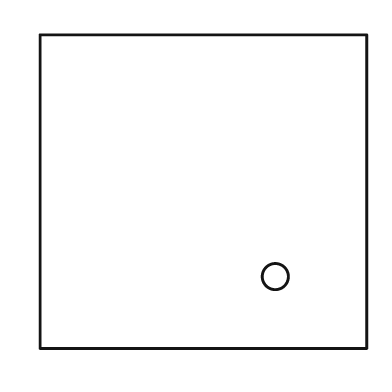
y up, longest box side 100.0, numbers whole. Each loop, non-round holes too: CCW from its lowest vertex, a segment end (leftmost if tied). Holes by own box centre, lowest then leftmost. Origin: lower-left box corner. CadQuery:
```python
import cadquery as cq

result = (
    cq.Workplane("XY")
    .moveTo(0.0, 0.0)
    .lineTo(100.0, 0.0)
    .lineTo(100.0, 96.0)
    .lineTo(0.0, 96.0)
    .close()
    .moveTo(72.0, 22.0)
    .circle(4.0)
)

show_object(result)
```